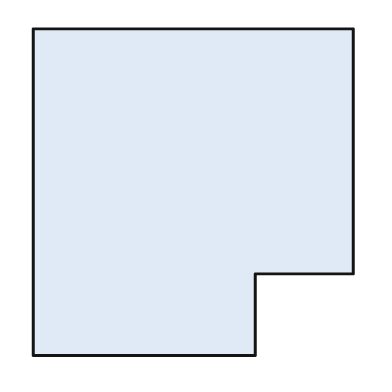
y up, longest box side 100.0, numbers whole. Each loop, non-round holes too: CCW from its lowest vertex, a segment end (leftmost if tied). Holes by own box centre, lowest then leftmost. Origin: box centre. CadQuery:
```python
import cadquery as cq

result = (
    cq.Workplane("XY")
    .moveTo(-49.0, -50.0)
    .lineTo(19.0, -50.0)
    .lineTo(19.0, -25.0)
    .lineTo(49.0, -25.0)
    .lineTo(49.0, 50.0)
    .lineTo(-49.0, 50.0)
    .close()
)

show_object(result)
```